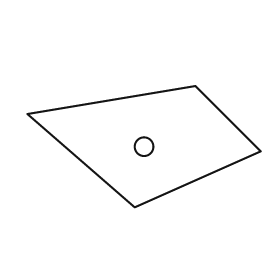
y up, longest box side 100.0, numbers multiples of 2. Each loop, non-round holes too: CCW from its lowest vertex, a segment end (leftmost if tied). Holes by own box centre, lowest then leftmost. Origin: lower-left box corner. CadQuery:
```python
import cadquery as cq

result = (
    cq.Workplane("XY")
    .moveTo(46.0, 0.0)
    .lineTo(100.0, 24.0)
    .lineTo(72.0, 52.0)
    .lineTo(0.0, 40.0)
    .close()
    .moveTo(50.0, 26.0)
    .circle(4.0)
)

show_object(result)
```